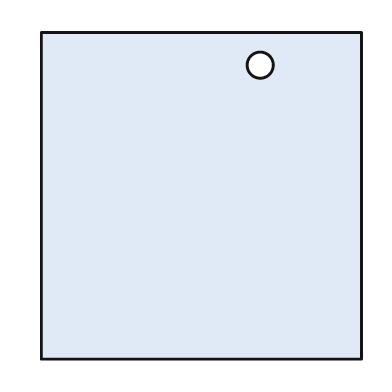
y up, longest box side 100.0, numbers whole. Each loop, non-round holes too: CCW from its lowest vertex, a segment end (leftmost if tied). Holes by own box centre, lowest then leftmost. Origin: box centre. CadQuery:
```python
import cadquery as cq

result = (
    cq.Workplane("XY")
    .moveTo(-49.0, -50.0)
    .lineTo(49.0, -50.0)
    .lineTo(49.0, 50.0)
    .lineTo(-49.0, 50.0)
    .close()
    .moveTo(18.0, 40.0)
    .circle(4.0)
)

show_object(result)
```